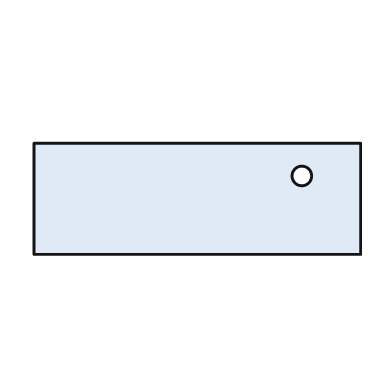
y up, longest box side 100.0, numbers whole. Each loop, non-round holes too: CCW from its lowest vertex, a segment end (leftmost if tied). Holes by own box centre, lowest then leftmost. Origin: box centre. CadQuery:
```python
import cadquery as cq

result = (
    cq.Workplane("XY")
    .moveTo(-50.0, -17.0)
    .lineTo(50.0, -17.0)
    .lineTo(50.0, 17.0)
    .lineTo(-50.0, 17.0)
    .close()
    .moveTo(32.0, 7.0)
    .circle(3.0)
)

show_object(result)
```